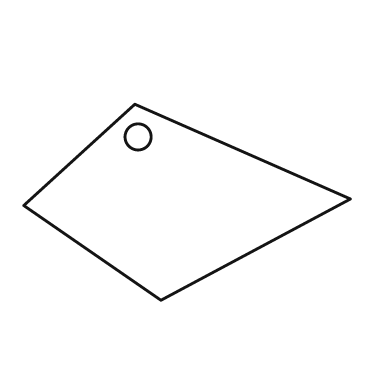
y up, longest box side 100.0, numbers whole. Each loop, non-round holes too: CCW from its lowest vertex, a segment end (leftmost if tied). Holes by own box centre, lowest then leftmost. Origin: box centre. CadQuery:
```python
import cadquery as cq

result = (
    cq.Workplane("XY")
    .moveTo(-8.0, -30.0)
    .lineTo(50.0, 1.0)
    .lineTo(-16.0, 30.0)
    .lineTo(-50.0, -1.0)
    .close()
    .moveTo(-15.0, 20.0)
    .circle(4.0)
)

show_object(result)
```